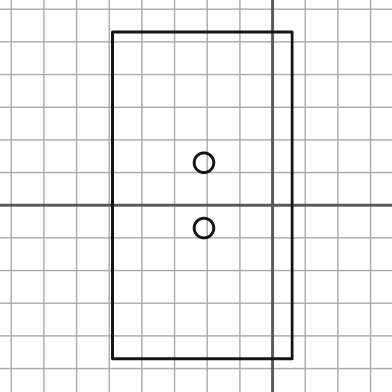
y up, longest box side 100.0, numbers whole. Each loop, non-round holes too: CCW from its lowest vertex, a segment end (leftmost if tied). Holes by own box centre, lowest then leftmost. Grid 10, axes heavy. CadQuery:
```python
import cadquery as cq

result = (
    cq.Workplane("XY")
    .moveTo(-49.0, -47.0)
    .lineTo(6.0, -47.0)
    .lineTo(6.0, 53.0)
    .lineTo(-49.0, 53.0)
    .close()
    .moveTo(-21.0, -7.0)
    .circle(3.0)
    .moveTo(-21.0, 13.0)
    .circle(3.0)
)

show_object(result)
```